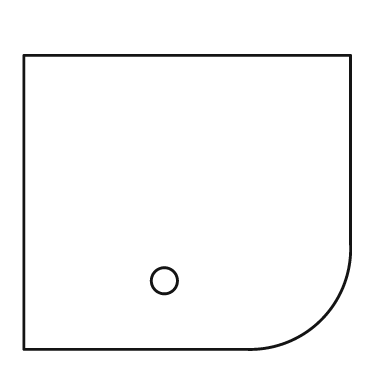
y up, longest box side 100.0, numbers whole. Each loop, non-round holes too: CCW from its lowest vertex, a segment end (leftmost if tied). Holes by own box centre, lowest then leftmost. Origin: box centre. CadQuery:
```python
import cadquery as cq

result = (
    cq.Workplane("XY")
    .moveTo(-50.0, -45.0)
    .lineTo(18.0, -45.0)
    .threePointArc((41.0, -36.0), (50.0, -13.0))
    .lineTo(50.0, 45.0)
    .lineTo(-50.0, 45.0)
    .close()
    .moveTo(-7.0, -24.0)
    .circle(4.0)
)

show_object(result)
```